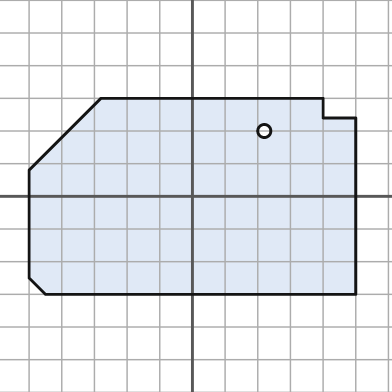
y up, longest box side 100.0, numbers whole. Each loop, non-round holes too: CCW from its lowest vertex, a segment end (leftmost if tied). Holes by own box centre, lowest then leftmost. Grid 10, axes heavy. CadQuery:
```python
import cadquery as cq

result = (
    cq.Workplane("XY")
    .moveTo(-45.0, -30.0)
    .lineTo(50.0, -30.0)
    .lineTo(50.0, 24.0)
    .lineTo(40.0, 24.0)
    .lineTo(40.0, 30.0)
    .lineTo(-28.0, 30.0)
    .lineTo(-50.0, 8.0)
    .lineTo(-50.0, -25.0)
    .close()
    .moveTo(22.0, 20.0)
    .circle(2.0)
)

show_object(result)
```